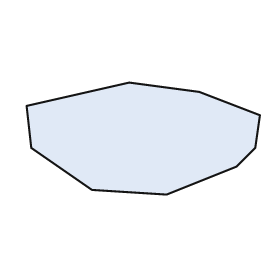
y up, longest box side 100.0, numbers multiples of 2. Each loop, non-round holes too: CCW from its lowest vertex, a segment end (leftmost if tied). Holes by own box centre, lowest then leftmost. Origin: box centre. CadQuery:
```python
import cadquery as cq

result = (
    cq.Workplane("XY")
    .moveTo(10.0, -24.0)
    .lineTo(40.0, -12.0)
    .lineTo(48.0, -4.0)
    .lineTo(50.0, 10.0)
    .lineTo(24.0, 20.0)
    .lineTo(-6.0, 24.0)
    .lineTo(-50.0, 14.0)
    .lineTo(-48.0, -4.0)
    .lineTo(-22.0, -22.0)
    .close()
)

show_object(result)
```